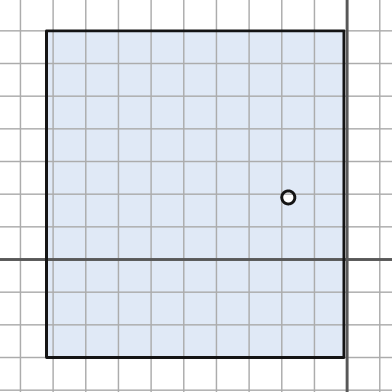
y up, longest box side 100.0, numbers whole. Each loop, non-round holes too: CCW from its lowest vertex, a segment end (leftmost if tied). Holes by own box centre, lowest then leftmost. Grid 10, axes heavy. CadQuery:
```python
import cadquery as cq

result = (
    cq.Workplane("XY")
    .moveTo(-92.0, -30.0)
    .lineTo(-1.0, -30.0)
    .lineTo(-1.0, 70.0)
    .lineTo(-92.0, 70.0)
    .close()
    .moveTo(-18.0, 19.0)
    .circle(2.0)
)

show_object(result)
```